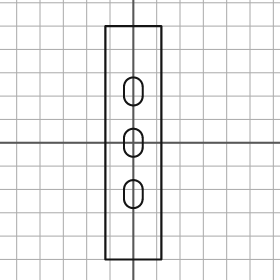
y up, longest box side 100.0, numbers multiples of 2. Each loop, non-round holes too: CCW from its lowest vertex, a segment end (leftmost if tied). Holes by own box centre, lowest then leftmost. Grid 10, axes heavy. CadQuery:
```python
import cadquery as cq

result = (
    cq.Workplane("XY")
    .moveTo(-12.0, -50.0)
    .lineTo(12.0, -50.0)
    .lineTo(12.0, 50.0)
    .lineTo(-12.0, 50.0)
    .close()
    .moveTo(-4.0, -24.0)
    .threePointArc((0.0, -28.0), (4.0, -24.0))
    .lineTo(4.0, -20.0)
    .threePointArc((0.0, -16.0), (-4.0, -20.0))
    .close()
    .moveTo(-4.0, -2.0)
    .threePointArc((0.0, -6.0), (4.0, -2.0))
    .lineTo(4.0, 2.0)
    .threePointArc((0.0, 6.0), (-4.0, 2.0))
    .close()
    .moveTo(-4.0, 20.0)
    .threePointArc((0.0, 16.0), (4.0, 20.0))
    .lineTo(4.0, 24.0)
    .threePointArc((0.0, 28.0), (-4.0, 24.0))
    .close()
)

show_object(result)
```